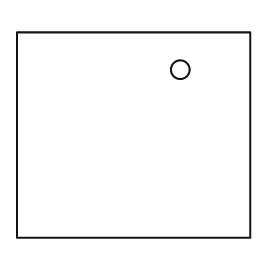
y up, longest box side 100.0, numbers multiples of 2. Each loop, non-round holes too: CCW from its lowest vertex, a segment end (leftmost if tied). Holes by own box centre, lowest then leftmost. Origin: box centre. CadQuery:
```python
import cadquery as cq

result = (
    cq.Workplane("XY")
    .moveTo(-50.0, -44.0)
    .lineTo(50.0, -44.0)
    .lineTo(50.0, 44.0)
    .lineTo(-50.0, 44.0)
    .close()
    .moveTo(20.0, 28.0)
    .circle(4.0)
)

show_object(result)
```